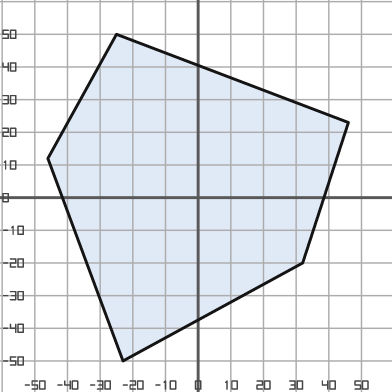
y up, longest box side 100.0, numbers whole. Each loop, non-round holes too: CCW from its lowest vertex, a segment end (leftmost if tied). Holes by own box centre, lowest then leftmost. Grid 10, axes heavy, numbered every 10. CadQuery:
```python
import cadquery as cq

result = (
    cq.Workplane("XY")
    .moveTo(-23.0, -50.0)
    .lineTo(32.0, -20.0)
    .lineTo(46.0, 23.0)
    .lineTo(-25.0, 50.0)
    .lineTo(-46.0, 12.0)
    .close()
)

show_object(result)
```